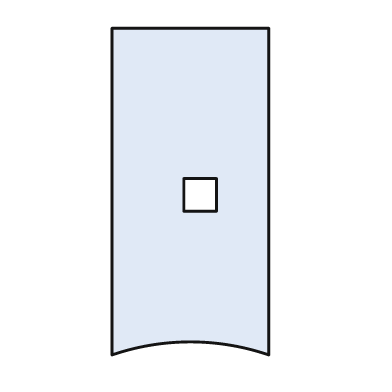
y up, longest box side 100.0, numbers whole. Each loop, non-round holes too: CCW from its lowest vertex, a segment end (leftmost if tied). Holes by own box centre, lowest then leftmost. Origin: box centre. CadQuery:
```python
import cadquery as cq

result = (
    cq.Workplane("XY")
    .moveTo(-24.0, -50.0)
    .threePointArc((0.0, -46.0), (24.0, -50.0))
    .lineTo(24.0, 50.0)
    .lineTo(-24.0, 50.0)
    .close()
    .moveTo(-2.0, -6.0)
    .lineTo(8.0, -6.0)
    .lineTo(8.0, 4.0)
    .lineTo(-2.0, 4.0)
    .close()
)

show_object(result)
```